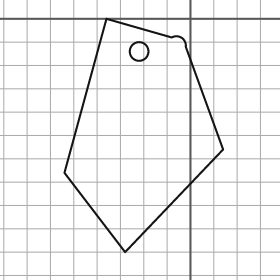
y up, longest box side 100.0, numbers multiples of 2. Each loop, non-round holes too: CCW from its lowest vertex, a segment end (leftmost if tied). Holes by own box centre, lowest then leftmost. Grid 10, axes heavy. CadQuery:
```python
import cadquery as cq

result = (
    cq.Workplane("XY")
    .moveTo(-28.0, -100.0)
    .lineTo(14.0, -56.0)
    .lineTo(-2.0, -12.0)
    .threePointArc((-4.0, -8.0), (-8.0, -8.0))
    .lineTo(-36.0, 0.0)
    .lineTo(-54.0, -66.0)
    .close()
    .moveTo(-22.0, -14.0)
    .circle(4.0)
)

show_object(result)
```